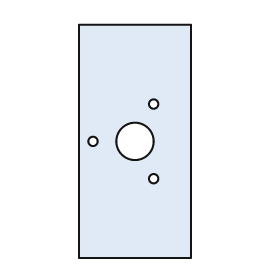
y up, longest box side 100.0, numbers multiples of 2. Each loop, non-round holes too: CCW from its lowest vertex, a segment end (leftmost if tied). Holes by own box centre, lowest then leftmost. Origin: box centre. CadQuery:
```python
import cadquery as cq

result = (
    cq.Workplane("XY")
    .moveTo(-24.0, -50.0)
    .lineTo(24.0, -50.0)
    .lineTo(24.0, 50.0)
    .lineTo(-24.0, 50.0)
    .close()
    .moveTo(8.0, -16.0)
    .circle(2.0)
    .moveTo(-18.0, 0.0)
    .circle(2.0)
    .moveTo(0.0, 0.0)
    .circle(8.0)
    .moveTo(8.0, 16.0)
    .circle(2.0)
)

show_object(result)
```